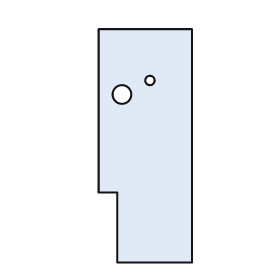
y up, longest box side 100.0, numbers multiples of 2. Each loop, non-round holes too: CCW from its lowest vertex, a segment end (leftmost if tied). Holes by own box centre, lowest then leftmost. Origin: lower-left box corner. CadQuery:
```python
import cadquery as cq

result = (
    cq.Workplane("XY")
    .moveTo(8.0, 0.0)
    .lineTo(40.0, 0.0)
    .lineTo(40.0, 100.0)
    .lineTo(0.0, 100.0)
    .lineTo(0.0, 30.0)
    .lineTo(8.0, 30.0)
    .close()
    .moveTo(10.0, 72.0)
    .circle(4.0)
    .moveTo(22.0, 78.0)
    .circle(2.0)
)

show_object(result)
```